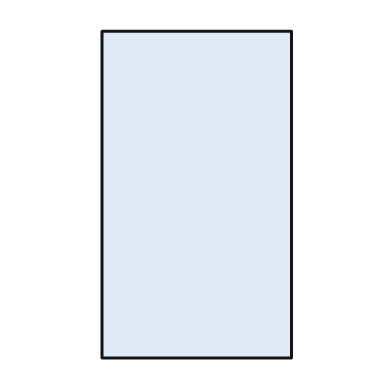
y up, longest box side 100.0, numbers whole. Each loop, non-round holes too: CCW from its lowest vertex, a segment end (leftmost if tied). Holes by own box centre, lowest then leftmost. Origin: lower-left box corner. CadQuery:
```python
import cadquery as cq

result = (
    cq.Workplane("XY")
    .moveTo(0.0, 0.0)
    .lineTo(58.0, 0.0)
    .lineTo(58.0, 100.0)
    .lineTo(0.0, 100.0)
    .close()
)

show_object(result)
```